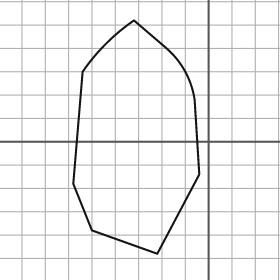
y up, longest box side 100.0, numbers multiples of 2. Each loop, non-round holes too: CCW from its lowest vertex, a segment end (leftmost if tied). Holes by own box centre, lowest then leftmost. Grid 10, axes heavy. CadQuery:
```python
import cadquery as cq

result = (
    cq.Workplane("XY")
    .moveTo(-22.0, -48.0)
    .lineTo(-4.0, -14.0)
    .lineTo(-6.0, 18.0)
    .threePointArc((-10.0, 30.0), (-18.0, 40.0))
    .lineTo(-32.0, 52.0)
    .threePointArc((-44.0, 42.0), (-54.0, 30.0))
    .lineTo(-58.0, -18.0)
    .lineTo(-50.0, -38.0)
    .close()
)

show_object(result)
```